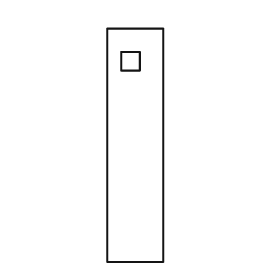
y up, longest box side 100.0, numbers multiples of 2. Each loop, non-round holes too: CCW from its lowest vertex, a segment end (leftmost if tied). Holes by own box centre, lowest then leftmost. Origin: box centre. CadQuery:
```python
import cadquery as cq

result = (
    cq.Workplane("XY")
    .moveTo(-12.0, -50.0)
    .lineTo(12.0, -50.0)
    .lineTo(12.0, 50.0)
    .lineTo(-12.0, 50.0)
    .close()
    .moveTo(-6.0, 32.0)
    .lineTo(2.0, 32.0)
    .lineTo(2.0, 40.0)
    .lineTo(-6.0, 40.0)
    .close()
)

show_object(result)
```